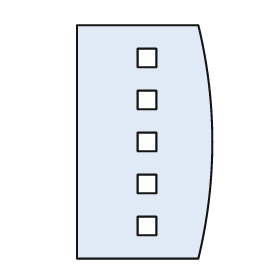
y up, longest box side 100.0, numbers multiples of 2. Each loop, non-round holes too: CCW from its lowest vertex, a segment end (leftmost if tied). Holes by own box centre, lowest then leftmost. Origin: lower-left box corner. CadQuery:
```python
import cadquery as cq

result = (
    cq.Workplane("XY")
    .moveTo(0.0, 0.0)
    .lineTo(52.0, 0.0)
    .threePointArc((58.0, 50.0), (52.0, 100.0))
    .lineTo(0.0, 100.0)
    .close()
    .moveTo(26.0, 10.0)
    .lineTo(34.0, 10.0)
    .lineTo(34.0, 18.0)
    .lineTo(26.0, 18.0)
    .close()
    .moveTo(26.0, 28.0)
    .lineTo(34.0, 28.0)
    .lineTo(34.0, 36.0)
    .lineTo(26.0, 36.0)
    .close()
    .moveTo(26.0, 46.0)
    .lineTo(34.0, 46.0)
    .lineTo(34.0, 54.0)
    .lineTo(26.0, 54.0)
    .close()
    .moveTo(26.0, 64.0)
    .lineTo(34.0, 64.0)
    .lineTo(34.0, 72.0)
    .lineTo(26.0, 72.0)
    .close()
    .moveTo(26.0, 82.0)
    .lineTo(34.0, 82.0)
    .lineTo(34.0, 90.0)
    .lineTo(26.0, 90.0)
    .close()
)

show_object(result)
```